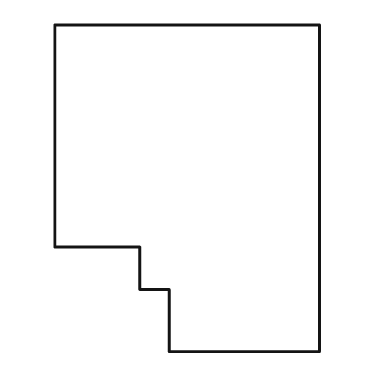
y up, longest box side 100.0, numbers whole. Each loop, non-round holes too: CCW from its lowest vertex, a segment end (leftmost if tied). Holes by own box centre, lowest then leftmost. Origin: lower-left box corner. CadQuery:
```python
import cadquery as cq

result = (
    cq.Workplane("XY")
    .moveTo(35.0, 0.0)
    .lineTo(81.0, 0.0)
    .lineTo(81.0, 100.0)
    .lineTo(0.0, 100.0)
    .lineTo(0.0, 32.0)
    .lineTo(26.0, 32.0)
    .lineTo(26.0, 19.0)
    .lineTo(35.0, 19.0)
    .close()
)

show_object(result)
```